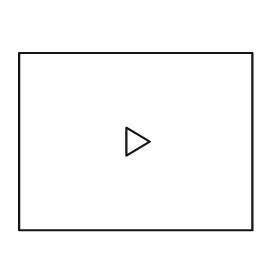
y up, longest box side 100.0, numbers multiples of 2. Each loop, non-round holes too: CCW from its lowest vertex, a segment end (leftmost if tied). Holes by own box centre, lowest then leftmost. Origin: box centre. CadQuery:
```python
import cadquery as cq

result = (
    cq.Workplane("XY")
    .moveTo(-50.0, -38.0)
    .lineTo(50.0, -38.0)
    .lineTo(50.0, 38.0)
    .lineTo(-50.0, 38.0)
    .close()
    .moveTo(-4.0, -6.0)
    .lineTo(6.0, 0.0)
    .lineTo(-4.0, 6.0)
    .close()
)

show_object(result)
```